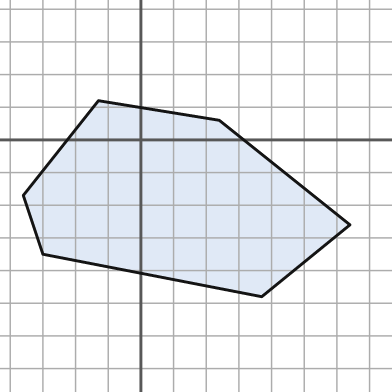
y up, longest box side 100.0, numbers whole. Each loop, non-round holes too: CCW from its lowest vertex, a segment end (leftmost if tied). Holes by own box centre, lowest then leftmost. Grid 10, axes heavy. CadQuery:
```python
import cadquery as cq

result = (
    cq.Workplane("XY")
    .moveTo(37.0, -48.0)
    .lineTo(64.0, -26.0)
    .lineTo(24.0, 6.0)
    .lineTo(-13.0, 12.0)
    .lineTo(-36.0, -17.0)
    .lineTo(-30.0, -35.0)
    .close()
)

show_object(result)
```